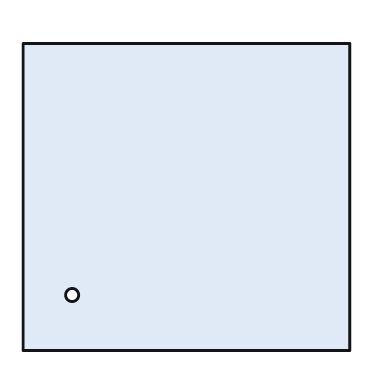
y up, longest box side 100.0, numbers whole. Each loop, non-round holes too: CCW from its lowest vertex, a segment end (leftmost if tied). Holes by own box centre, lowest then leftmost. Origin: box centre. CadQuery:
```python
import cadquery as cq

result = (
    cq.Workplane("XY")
    .moveTo(-50.0, -47.0)
    .lineTo(50.0, -47.0)
    .lineTo(50.0, 47.0)
    .lineTo(-50.0, 47.0)
    .close()
    .moveTo(-35.0, -30.0)
    .circle(2.0)
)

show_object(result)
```